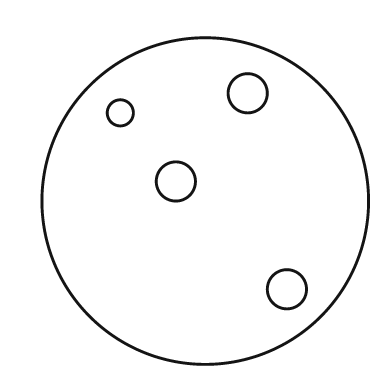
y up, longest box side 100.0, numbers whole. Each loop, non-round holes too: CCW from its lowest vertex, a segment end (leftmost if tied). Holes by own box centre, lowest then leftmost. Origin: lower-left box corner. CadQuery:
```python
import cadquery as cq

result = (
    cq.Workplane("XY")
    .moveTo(50.0, 50.0)
    .circle(50.0)
    .moveTo(75.0, 23.0)
    .circle(6.0)
    .moveTo(41.0, 56.0)
    .circle(6.0)
    .moveTo(24.0, 77.0)
    .circle(4.0)
    .moveTo(63.0, 83.0)
    .circle(6.0)
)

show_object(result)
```